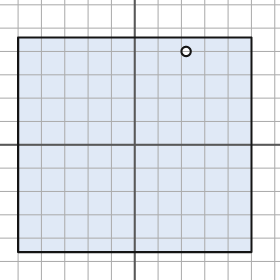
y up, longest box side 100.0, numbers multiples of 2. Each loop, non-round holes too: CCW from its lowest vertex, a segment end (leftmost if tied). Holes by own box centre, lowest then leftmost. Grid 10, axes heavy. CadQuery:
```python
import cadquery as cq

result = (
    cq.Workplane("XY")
    .moveTo(-50.0, -46.0)
    .lineTo(50.0, -46.0)
    .lineTo(50.0, 46.0)
    .lineTo(-50.0, 46.0)
    .close()
    .moveTo(22.0, 40.0)
    .circle(2.0)
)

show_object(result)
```